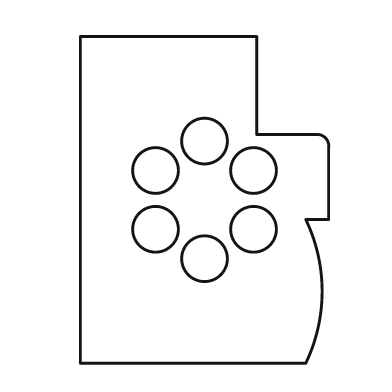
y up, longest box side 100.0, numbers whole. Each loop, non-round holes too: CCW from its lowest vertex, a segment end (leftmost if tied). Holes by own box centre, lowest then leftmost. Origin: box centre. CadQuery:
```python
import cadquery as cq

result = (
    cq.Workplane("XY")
    .moveTo(-38.0, -50.0)
    .lineTo(31.0, -50.0)
    .threePointArc((36.0, -28.0), (31.0, -6.0))
    .lineTo(38.0, -6.0)
    .lineTo(38.0, 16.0)
    .threePointArc((37.0, 19.0), (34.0, 20.0))
    .lineTo(16.0, 20.0)
    .lineTo(16.0, 50.0)
    .lineTo(-38.0, 50.0)
    .close()
    .moveTo(0.0, -18.0)
    .circle(7.0)
    .moveTo(-15.0, -9.0)
    .circle(7.0)
    .moveTo(15.0, -9.0)
    .circle(7.0)
    .moveTo(-15.0, 9.0)
    .circle(7.0)
    .moveTo(15.0, 9.0)
    .circle(7.0)
    .moveTo(0.0, 18.0)
    .circle(7.0)
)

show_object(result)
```